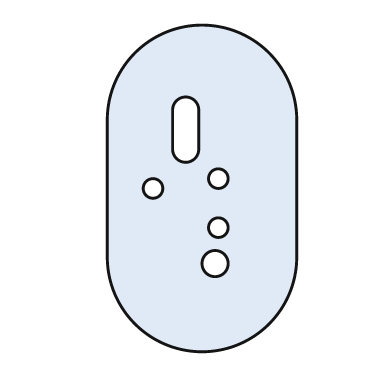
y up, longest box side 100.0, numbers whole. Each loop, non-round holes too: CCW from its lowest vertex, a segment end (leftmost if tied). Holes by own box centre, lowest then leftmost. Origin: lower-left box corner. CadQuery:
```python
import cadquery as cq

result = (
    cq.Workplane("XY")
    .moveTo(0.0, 29.0)
    .threePointArc((29.0, 0.0), (58.0, 29.0))
    .lineTo(58.0, 71.0)
    .threePointArc((29.0, 100.0), (0.0, 71.0))
    .close()
    .moveTo(33.0, 27.0)
    .circle(4.0)
    .moveTo(34.0, 38.0)
    .circle(3.0)
    .moveTo(14.0, 50.0)
    .circle(3.0)
    .moveTo(34.0, 53.0)
    .circle(3.0)
    .moveTo(20.0, 62.0)
    .threePointArc((24.0, 58.0), (28.0, 62.0))
    .lineTo(28.0, 74.0)
    .threePointArc((24.0, 78.0), (20.0, 74.0))
    .close()
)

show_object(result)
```